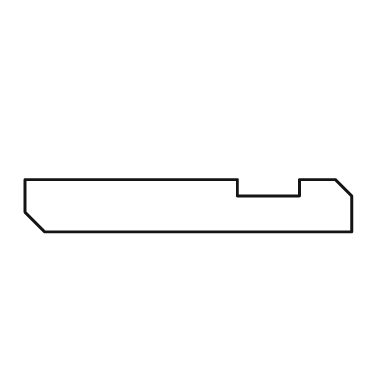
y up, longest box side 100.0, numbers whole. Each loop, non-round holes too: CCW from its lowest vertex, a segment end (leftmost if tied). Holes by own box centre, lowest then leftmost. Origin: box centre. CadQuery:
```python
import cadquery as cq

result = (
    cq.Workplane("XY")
    .moveTo(-44.0, -8.0)
    .lineTo(50.0, -8.0)
    .lineTo(50.0, 3.0)
    .lineTo(45.0, 8.0)
    .lineTo(34.0, 8.0)
    .lineTo(34.0, 3.0)
    .lineTo(15.0, 3.0)
    .lineTo(15.0, 8.0)
    .lineTo(-50.0, 8.0)
    .lineTo(-50.0, -2.0)
    .close()
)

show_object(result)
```